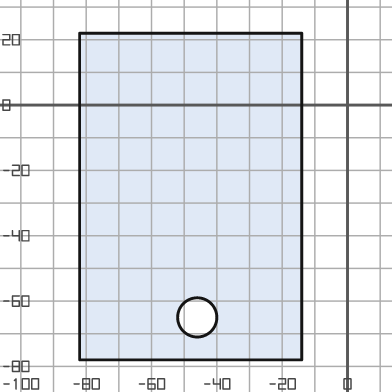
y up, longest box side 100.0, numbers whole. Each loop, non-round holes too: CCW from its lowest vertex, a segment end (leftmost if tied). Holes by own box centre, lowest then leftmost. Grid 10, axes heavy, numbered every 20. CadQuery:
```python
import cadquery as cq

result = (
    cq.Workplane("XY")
    .moveTo(-82.0, -78.0)
    .lineTo(-14.0, -78.0)
    .lineTo(-14.0, 22.0)
    .lineTo(-82.0, 22.0)
    .close()
    .moveTo(-46.0, -65.0)
    .circle(6.0)
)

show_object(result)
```